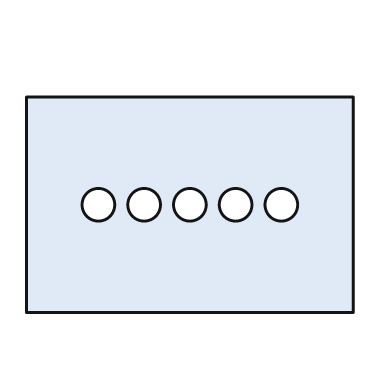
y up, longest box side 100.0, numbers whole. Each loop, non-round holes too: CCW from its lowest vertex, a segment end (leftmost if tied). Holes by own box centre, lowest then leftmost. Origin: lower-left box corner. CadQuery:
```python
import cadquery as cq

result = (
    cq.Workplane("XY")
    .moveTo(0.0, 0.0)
    .lineTo(100.0, 0.0)
    .lineTo(100.0, 66.0)
    .lineTo(0.0, 66.0)
    .close()
    .moveTo(22.0, 33.0)
    .circle(5.0)
    .moveTo(36.0, 33.0)
    .circle(5.0)
    .moveTo(50.0, 33.0)
    .circle(5.0)
    .moveTo(64.0, 33.0)
    .circle(5.0)
    .moveTo(78.0, 33.0)
    .circle(5.0)
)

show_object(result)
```